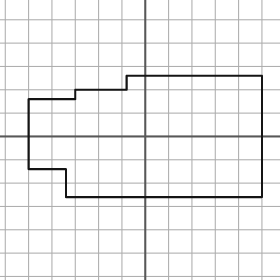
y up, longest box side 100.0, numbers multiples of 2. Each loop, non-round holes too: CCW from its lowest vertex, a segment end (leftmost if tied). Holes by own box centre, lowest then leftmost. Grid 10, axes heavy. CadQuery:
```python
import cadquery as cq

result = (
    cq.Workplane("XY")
    .moveTo(-34.0, -26.0)
    .lineTo(50.0, -26.0)
    .lineTo(50.0, 26.0)
    .lineTo(-8.0, 26.0)
    .lineTo(-8.0, 20.0)
    .lineTo(-30.0, 20.0)
    .lineTo(-30.0, 16.0)
    .lineTo(-50.0, 16.0)
    .lineTo(-50.0, -14.0)
    .lineTo(-34.0, -14.0)
    .close()
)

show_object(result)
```